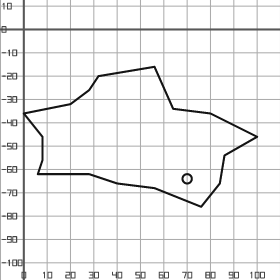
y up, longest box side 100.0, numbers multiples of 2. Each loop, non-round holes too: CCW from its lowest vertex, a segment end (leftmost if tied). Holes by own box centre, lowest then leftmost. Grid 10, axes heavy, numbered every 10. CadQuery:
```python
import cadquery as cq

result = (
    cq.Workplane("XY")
    .moveTo(76.0, -76.0)
    .lineTo(84.0, -66.0)
    .lineTo(86.0, -54.0)
    .lineTo(100.0, -46.0)
    .lineTo(80.0, -36.0)
    .lineTo(64.0, -34.0)
    .lineTo(56.0, -16.0)
    .lineTo(32.0, -20.0)
    .lineTo(28.0, -26.0)
    .lineTo(20.0, -32.0)
    .lineTo(0.0, -36.0)
    .lineTo(8.0, -46.0)
    .lineTo(8.0, -56.0)
    .lineTo(6.0, -62.0)
    .lineTo(28.0, -62.0)
    .lineTo(40.0, -66.0)
    .lineTo(56.0, -68.0)
    .close()
    .moveTo(70.0, -64.0)
    .circle(2.0)
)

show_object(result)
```